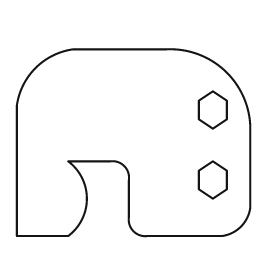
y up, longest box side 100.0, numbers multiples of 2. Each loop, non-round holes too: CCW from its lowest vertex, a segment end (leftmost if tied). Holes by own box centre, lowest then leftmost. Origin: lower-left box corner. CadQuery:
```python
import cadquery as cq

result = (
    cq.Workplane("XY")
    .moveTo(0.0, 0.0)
    .lineTo(22.0, 0.0)
    .threePointArc((30.0, 16.0), (22.0, 32.0))
    .lineTo(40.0, 32.0)
    .threePointArc((46.0, 30.0), (48.0, 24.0))
    .lineTo(48.0, 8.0)
    .threePointArc((50.0, 2.0), (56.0, 0.0))
    .lineTo(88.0, 0.0)
    .threePointArc((96.0, 4.0), (100.0, 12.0))
    .lineTo(100.0, 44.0)
    .threePointArc((90.0, 70.0), (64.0, 80.0))
    .lineTo(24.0, 80.0)
    .threePointArc((8.0, 72.0), (0.0, 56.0))
    .close()
    .moveTo(84.0, 16.0)
    .lineTo(90.0, 20.0)
    .lineTo(90.0, 28.0)
    .lineTo(84.0, 32.0)
    .lineTo(78.0, 28.0)
    .lineTo(78.0, 20.0)
    .close()
    .moveTo(84.0, 46.0)
    .lineTo(90.0, 50.0)
    .lineTo(90.0, 58.0)
    .lineTo(84.0, 62.0)
    .lineTo(78.0, 58.0)
    .lineTo(78.0, 50.0)
    .close()
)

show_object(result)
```